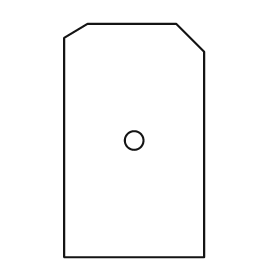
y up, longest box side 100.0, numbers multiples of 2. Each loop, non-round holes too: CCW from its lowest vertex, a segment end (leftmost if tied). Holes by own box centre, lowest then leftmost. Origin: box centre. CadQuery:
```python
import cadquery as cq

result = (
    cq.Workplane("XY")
    .moveTo(-30.0, -50.0)
    .lineTo(30.0, -50.0)
    .lineTo(30.0, 38.0)
    .lineTo(18.0, 50.0)
    .lineTo(-20.0, 50.0)
    .lineTo(-30.0, 44.0)
    .close()
    .moveTo(0.0, 0.0)
    .circle(4.0)
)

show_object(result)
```